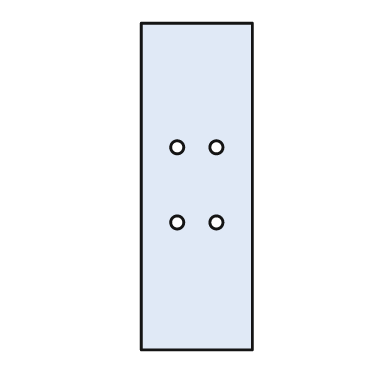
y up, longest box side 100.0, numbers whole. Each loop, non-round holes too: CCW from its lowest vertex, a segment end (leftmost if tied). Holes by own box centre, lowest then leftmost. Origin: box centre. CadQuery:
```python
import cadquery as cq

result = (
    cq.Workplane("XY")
    .moveTo(-17.0, -50.0)
    .lineTo(17.0, -50.0)
    .lineTo(17.0, 50.0)
    .lineTo(-17.0, 50.0)
    .close()
    .moveTo(-6.0, -11.0)
    .circle(2.0)
    .moveTo(6.0, -11.0)
    .circle(2.0)
    .moveTo(-6.0, 12.0)
    .circle(2.0)
    .moveTo(6.0, 12.0)
    .circle(2.0)
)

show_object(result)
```